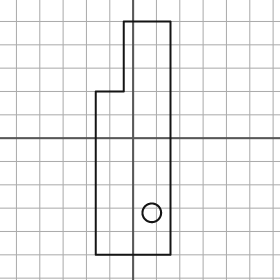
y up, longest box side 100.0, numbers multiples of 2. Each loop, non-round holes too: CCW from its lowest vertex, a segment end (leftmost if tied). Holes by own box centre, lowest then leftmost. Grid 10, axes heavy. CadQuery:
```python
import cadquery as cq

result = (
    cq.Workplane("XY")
    .moveTo(-16.0, -50.0)
    .lineTo(16.0, -50.0)
    .lineTo(16.0, 50.0)
    .lineTo(-4.0, 50.0)
    .lineTo(-4.0, 20.0)
    .lineTo(-16.0, 20.0)
    .close()
    .moveTo(8.0, -32.0)
    .circle(4.0)
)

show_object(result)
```